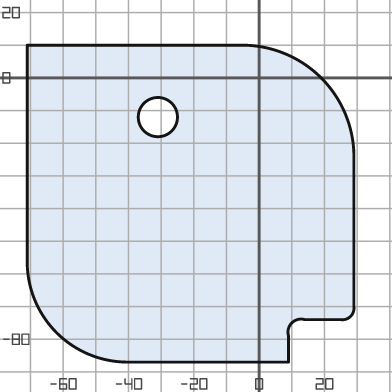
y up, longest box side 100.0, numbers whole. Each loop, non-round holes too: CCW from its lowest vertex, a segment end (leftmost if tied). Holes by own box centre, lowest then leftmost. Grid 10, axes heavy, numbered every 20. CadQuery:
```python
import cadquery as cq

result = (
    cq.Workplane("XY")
    .moveTo(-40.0, -87.0)
    .lineTo(9.0, -87.0)
    .lineTo(9.0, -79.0)
    .threePointArc((10.0, -75.0), (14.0, -74.0))
    .lineTo(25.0, -74.0)
    .threePointArc((28.0, -73.0), (29.0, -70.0))
    .lineTo(29.0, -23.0)
    .threePointArc((19.0, 0.0), (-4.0, 10.0))
    .lineTo(-71.0, 10.0)
    .lineTo(-71.0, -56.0)
    .threePointArc((-62.0, -78.0), (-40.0, -87.0))
    .close()
    .moveTo(-31.0, -12.0)
    .circle(6.0)
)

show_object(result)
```